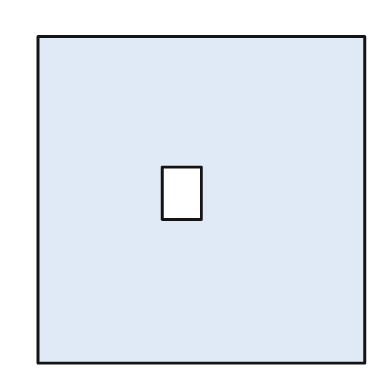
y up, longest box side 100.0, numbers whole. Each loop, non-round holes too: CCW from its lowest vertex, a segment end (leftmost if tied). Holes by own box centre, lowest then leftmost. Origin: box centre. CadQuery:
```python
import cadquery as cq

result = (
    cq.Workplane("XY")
    .moveTo(-50.0, -50.0)
    .lineTo(50.0, -50.0)
    .lineTo(50.0, 50.0)
    .lineTo(-50.0, 50.0)
    .close()
    .moveTo(-12.0, -6.0)
    .lineTo(0.0, -6.0)
    .lineTo(0.0, 10.0)
    .lineTo(-12.0, 10.0)
    .close()
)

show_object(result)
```